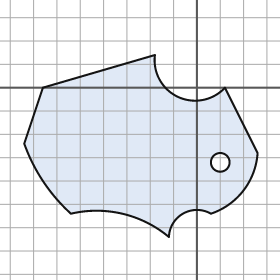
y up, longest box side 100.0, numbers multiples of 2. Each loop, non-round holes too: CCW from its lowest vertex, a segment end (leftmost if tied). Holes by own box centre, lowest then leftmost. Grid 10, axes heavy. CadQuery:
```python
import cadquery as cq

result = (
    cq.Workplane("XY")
    .moveTo(-12.0, -64.0)
    .threePointArc((-6.0, -54.0), (6.0, -54.0))
    .threePointArc((20.0, -44.0), (26.0, -28.0))
    .lineTo(12.0, 0.0)
    .threePointArc((-8.0, -4.0), (-18.0, 14.0))
    .lineTo(-66.0, 0.0)
    .lineTo(-74.0, -24.0)
    .threePointArc((-66.0, -40.0), (-54.0, -54.0))
    .threePointArc((-32.0, -54.0), (-12.0, -64.0))
    .close()
    .moveTo(10.0, -32.0)
    .circle(4.0)
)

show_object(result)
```